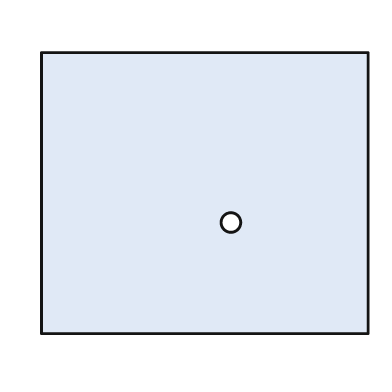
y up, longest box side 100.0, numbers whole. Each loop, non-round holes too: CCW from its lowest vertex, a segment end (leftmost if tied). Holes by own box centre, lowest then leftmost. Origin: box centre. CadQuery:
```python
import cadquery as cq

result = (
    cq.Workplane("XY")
    .moveTo(-50.0, -43.0)
    .lineTo(50.0, -43.0)
    .lineTo(50.0, 43.0)
    .lineTo(-50.0, 43.0)
    .close()
    .moveTo(8.0, -9.0)
    .circle(3.0)
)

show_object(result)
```